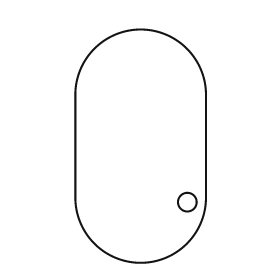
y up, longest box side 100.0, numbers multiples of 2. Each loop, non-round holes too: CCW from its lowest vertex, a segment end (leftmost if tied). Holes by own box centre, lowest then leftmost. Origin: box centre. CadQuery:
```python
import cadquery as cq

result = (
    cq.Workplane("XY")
    .moveTo(-28.0, -22.0)
    .threePointArc((0.0, -50.0), (28.0, -22.0))
    .lineTo(28.0, 22.0)
    .threePointArc((0.0, 50.0), (-28.0, 22.0))
    .close()
    .moveTo(20.0, -24.0)
    .circle(4.0)
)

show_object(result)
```